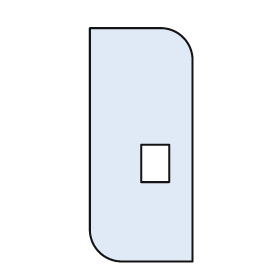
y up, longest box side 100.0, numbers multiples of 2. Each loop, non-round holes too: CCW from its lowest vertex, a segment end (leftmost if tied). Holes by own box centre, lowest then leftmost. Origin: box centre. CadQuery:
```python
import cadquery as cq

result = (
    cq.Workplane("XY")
    .moveTo(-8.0, -50.0)
    .lineTo(22.0, -50.0)
    .lineTo(22.0, 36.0)
    .threePointArc((18.0, 46.0), (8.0, 50.0))
    .lineTo(-22.0, 50.0)
    .lineTo(-22.0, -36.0)
    .threePointArc((-18.0, -46.0), (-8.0, -50.0))
    .close()
    .moveTo(0.0, -16.0)
    .lineTo(12.0, -16.0)
    .lineTo(12.0, 0.0)
    .lineTo(0.0, 0.0)
    .close()
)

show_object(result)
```